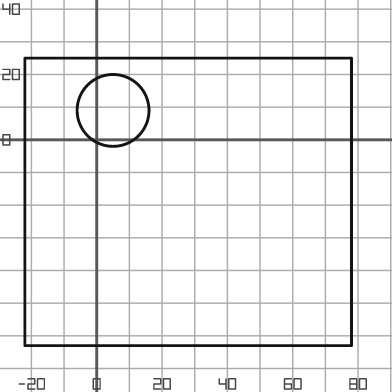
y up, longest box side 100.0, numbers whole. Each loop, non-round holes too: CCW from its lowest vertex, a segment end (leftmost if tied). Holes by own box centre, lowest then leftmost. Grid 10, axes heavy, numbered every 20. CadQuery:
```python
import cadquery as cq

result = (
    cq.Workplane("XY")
    .moveTo(-22.0, -63.0)
    .lineTo(78.0, -63.0)
    .lineTo(78.0, 25.0)
    .lineTo(-22.0, 25.0)
    .close()
    .moveTo(5.0, 9.0)
    .circle(11.0)
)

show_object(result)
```